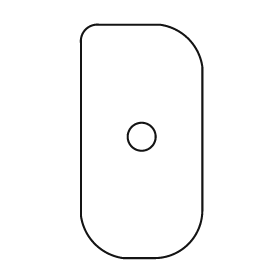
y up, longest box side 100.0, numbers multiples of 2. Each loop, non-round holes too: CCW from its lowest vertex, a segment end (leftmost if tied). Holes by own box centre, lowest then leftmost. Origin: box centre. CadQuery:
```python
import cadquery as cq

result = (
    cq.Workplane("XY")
    .moveTo(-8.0, -50.0)
    .lineTo(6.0, -50.0)
    .threePointArc((20.0, -44.0), (26.0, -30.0))
    .lineTo(26.0, 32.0)
    .threePointArc((20.0, 44.0), (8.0, 50.0))
    .lineTo(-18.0, 50.0)
    .threePointArc((-24.0, 48.0), (-26.0, 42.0))
    .lineTo(-26.0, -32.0)
    .threePointArc((-20.0, -44.0), (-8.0, -50.0))
    .close()
    .moveTo(0.0, 2.0)
    .circle(6.0)
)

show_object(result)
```